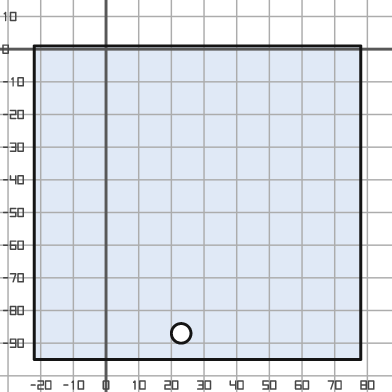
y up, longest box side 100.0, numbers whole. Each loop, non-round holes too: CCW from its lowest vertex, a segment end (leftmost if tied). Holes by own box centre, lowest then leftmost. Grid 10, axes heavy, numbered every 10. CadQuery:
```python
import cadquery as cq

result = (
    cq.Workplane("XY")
    .moveTo(-22.0, -95.0)
    .lineTo(78.0, -95.0)
    .lineTo(78.0, 1.0)
    .lineTo(-22.0, 1.0)
    .close()
    .moveTo(23.0, -87.0)
    .circle(3.0)
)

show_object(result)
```